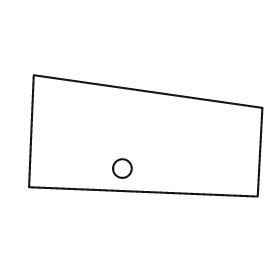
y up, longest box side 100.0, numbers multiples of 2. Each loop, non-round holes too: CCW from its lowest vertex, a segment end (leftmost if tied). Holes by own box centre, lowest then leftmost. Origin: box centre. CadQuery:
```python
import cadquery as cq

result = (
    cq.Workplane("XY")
    .moveTo(48.0, -26.0)
    .lineTo(50.0, 12.0)
    .lineTo(-48.0, 26.0)
    .lineTo(-50.0, -22.0)
    .close()
    .moveTo(-10.0, -14.0)
    .circle(4.0)
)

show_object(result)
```